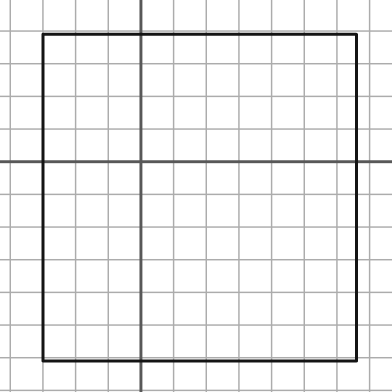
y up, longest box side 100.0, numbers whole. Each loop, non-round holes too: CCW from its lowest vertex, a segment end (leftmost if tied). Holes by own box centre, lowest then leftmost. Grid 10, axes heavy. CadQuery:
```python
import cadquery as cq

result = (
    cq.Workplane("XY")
    .moveTo(-30.0, -61.0)
    .lineTo(66.0, -61.0)
    .lineTo(66.0, 39.0)
    .lineTo(-30.0, 39.0)
    .close()
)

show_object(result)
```